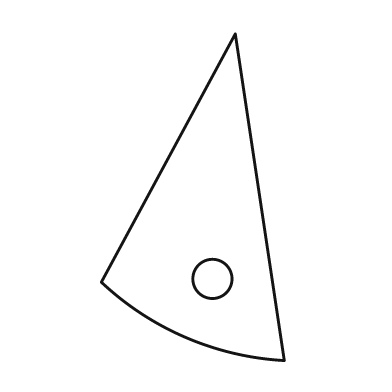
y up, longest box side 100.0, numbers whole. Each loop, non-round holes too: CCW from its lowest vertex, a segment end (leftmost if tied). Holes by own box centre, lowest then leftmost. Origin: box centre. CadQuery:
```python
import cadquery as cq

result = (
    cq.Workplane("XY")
    .moveTo(28.0, -50.0)
    .lineTo(13.0, 50.0)
    .lineTo(-28.0, -26.0)
    .threePointArc((-2.0, -43.0), (28.0, -50.0))
    .close()
    .moveTo(6.0, -25.0)
    .circle(6.0)
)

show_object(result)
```